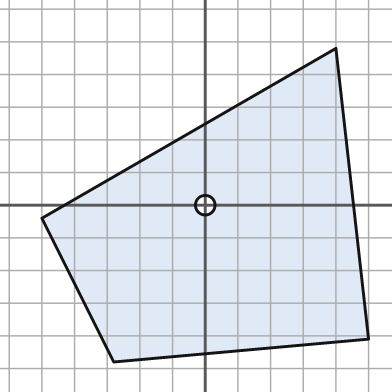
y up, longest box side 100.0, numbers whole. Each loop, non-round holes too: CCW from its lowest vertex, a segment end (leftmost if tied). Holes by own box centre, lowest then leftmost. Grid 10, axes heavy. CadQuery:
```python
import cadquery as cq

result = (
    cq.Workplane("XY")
    .moveTo(-28.0, -48.0)
    .lineTo(50.0, -41.0)
    .lineTo(40.0, 48.0)
    .lineTo(-50.0, -4.0)
    .close()
    .moveTo(0.0, 0.0)
    .circle(3.0)
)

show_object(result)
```